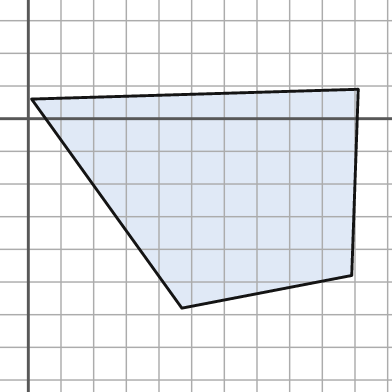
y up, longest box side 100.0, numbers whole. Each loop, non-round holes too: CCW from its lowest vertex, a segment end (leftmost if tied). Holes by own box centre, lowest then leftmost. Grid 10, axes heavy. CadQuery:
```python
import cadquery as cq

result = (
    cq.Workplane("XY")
    .moveTo(47.0, -58.0)
    .lineTo(99.0, -48.0)
    .lineTo(101.0, 9.0)
    .lineTo(1.0, 6.0)
    .close()
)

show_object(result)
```